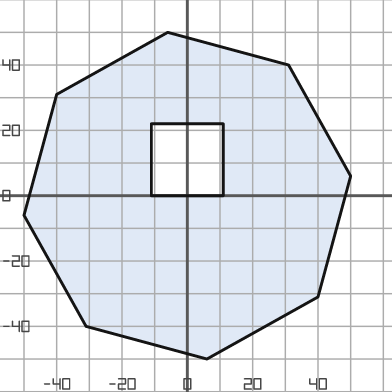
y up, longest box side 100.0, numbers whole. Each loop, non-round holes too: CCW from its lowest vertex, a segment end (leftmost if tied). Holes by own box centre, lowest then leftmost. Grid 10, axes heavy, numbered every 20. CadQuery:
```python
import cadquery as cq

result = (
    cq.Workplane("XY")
    .moveTo(6.0, -50.0)
    .lineTo(40.0, -31.0)
    .lineTo(50.0, 6.0)
    .lineTo(31.0, 40.0)
    .lineTo(-6.0, 50.0)
    .lineTo(-40.0, 31.0)
    .lineTo(-50.0, -6.0)
    .lineTo(-31.0, -40.0)
    .close()
    .moveTo(-11.0, 0.0)
    .lineTo(11.0, 0.0)
    .lineTo(11.0, 22.0)
    .lineTo(-11.0, 22.0)
    .close()
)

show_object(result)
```